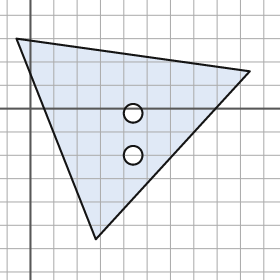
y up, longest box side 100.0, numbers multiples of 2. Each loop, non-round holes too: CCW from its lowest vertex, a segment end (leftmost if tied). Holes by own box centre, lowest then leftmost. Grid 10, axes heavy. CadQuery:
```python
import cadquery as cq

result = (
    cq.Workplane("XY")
    .moveTo(28.0, -56.0)
    .lineTo(94.0, 16.0)
    .lineTo(-6.0, 30.0)
    .close()
    .moveTo(44.0, -20.0)
    .circle(4.0)
    .moveTo(44.0, -2.0)
    .circle(4.0)
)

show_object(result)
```